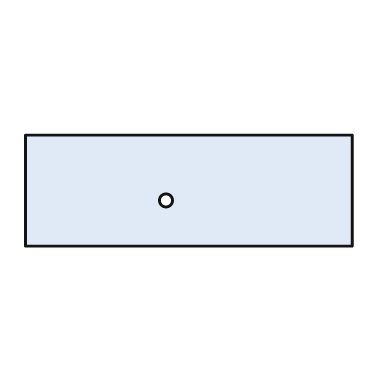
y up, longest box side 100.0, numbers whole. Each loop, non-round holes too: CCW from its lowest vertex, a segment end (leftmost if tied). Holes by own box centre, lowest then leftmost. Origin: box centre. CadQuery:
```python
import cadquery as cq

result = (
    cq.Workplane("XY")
    .moveTo(-50.0, -17.0)
    .lineTo(50.0, -17.0)
    .lineTo(50.0, 17.0)
    .lineTo(-50.0, 17.0)
    .close()
    .moveTo(-7.0, -3.0)
    .circle(2.0)
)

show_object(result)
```